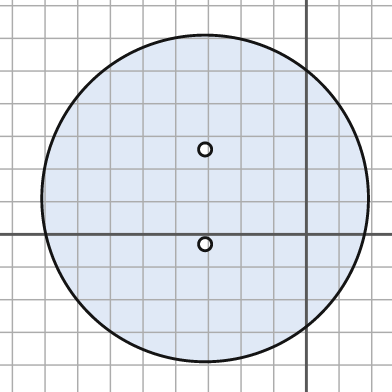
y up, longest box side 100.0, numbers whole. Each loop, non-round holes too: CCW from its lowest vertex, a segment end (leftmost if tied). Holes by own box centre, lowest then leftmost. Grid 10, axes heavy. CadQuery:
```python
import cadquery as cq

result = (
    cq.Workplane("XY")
    .moveTo(-31.0, 11.0)
    .circle(50.0)
    .moveTo(-31.0, -3.0)
    .circle(2.0)
    .moveTo(-31.0, 26.0)
    .circle(2.0)
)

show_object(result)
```